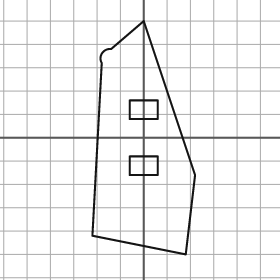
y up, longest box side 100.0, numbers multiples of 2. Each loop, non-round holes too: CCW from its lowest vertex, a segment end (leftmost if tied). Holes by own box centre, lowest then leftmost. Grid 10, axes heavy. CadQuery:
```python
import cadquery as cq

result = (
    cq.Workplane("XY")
    .moveTo(18.0, -50.0)
    .lineTo(22.0, -16.0)
    .lineTo(0.0, 50.0)
    .lineTo(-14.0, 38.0)
    .threePointArc((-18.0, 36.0), (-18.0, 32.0))
    .lineTo(-22.0, -42.0)
    .close()
    .moveTo(-6.0, -16.0)
    .lineTo(6.0, -16.0)
    .lineTo(6.0, -8.0)
    .lineTo(-6.0, -8.0)
    .close()
    .moveTo(-6.0, 8.0)
    .lineTo(6.0, 8.0)
    .lineTo(6.0, 16.0)
    .lineTo(-6.0, 16.0)
    .close()
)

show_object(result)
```